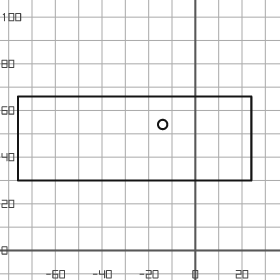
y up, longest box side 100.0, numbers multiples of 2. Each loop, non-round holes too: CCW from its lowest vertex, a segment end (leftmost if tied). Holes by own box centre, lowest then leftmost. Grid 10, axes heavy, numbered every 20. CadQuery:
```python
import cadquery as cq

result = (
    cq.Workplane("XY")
    .moveTo(-76.0, 30.0)
    .lineTo(24.0, 30.0)
    .lineTo(24.0, 66.0)
    .lineTo(-76.0, 66.0)
    .close()
    .moveTo(-14.0, 54.0)
    .circle(2.0)
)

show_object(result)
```